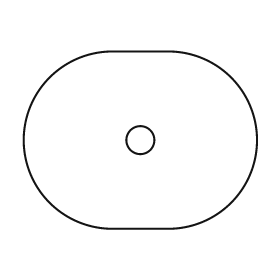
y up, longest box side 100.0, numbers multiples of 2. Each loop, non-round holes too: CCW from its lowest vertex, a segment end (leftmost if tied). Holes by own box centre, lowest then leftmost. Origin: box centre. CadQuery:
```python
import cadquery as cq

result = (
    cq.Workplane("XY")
    .moveTo(-12.0, -38.0)
    .lineTo(12.0, -38.0)
    .threePointArc((50.0, 0.0), (12.0, 38.0))
    .lineTo(-12.0, 38.0)
    .threePointArc((-50.0, 0.0), (-12.0, -38.0))
    .close()
    .moveTo(0.0, 0.0)
    .circle(6.0)
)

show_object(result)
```